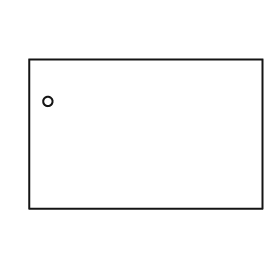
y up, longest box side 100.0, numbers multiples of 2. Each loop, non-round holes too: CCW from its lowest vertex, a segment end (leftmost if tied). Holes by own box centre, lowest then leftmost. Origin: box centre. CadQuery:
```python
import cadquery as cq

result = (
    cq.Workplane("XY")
    .moveTo(-50.0, -32.0)
    .lineTo(50.0, -32.0)
    .lineTo(50.0, 32.0)
    .lineTo(-50.0, 32.0)
    .close()
    .moveTo(-42.0, 14.0)
    .circle(2.0)
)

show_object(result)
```